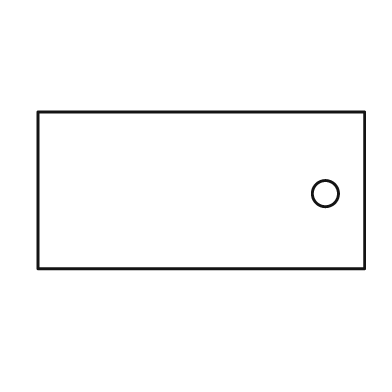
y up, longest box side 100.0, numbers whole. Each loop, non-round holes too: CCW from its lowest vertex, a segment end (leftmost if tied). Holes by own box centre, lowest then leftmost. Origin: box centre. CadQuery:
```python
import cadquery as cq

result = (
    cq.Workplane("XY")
    .moveTo(-50.0, -24.0)
    .lineTo(50.0, -24.0)
    .lineTo(50.0, 24.0)
    .lineTo(-50.0, 24.0)
    .close()
    .moveTo(38.0, -1.0)
    .circle(4.0)
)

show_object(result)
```